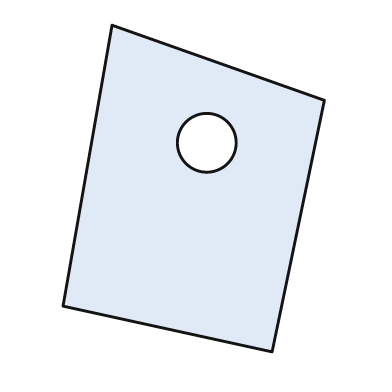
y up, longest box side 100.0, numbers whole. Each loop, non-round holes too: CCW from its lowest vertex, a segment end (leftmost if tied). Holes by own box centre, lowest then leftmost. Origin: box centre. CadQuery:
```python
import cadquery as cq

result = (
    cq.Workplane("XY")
    .moveTo(24.0, -50.0)
    .lineTo(40.0, 27.0)
    .lineTo(-25.0, 50.0)
    .lineTo(-40.0, -36.0)
    .close()
    .moveTo(4.0, 14.0)
    .circle(9.0)
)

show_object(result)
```